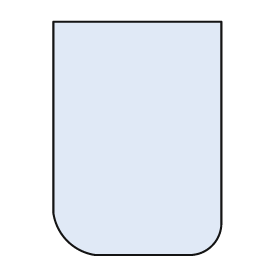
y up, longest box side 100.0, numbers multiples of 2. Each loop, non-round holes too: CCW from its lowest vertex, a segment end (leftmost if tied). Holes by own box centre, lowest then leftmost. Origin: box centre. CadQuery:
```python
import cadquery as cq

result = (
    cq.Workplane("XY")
    .moveTo(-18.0, -50.0)
    .lineTo(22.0, -50.0)
    .threePointArc((32.0, -46.0), (36.0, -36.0))
    .lineTo(36.0, 50.0)
    .lineTo(-36.0, 50.0)
    .lineTo(-36.0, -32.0)
    .threePointArc((-30.0, -44.0), (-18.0, -50.0))
    .close()
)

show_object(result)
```